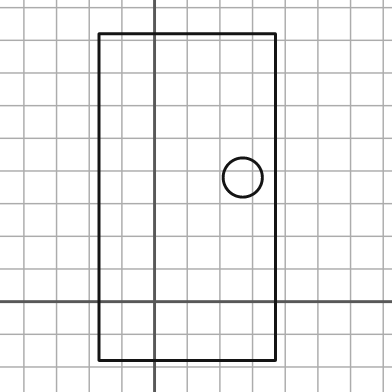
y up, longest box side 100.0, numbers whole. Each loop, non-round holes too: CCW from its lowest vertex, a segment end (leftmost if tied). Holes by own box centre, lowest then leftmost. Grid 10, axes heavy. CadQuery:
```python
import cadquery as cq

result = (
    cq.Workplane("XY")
    .moveTo(-17.0, -18.0)
    .lineTo(37.0, -18.0)
    .lineTo(37.0, 82.0)
    .lineTo(-17.0, 82.0)
    .close()
    .moveTo(27.0, 38.0)
    .circle(6.0)
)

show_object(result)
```